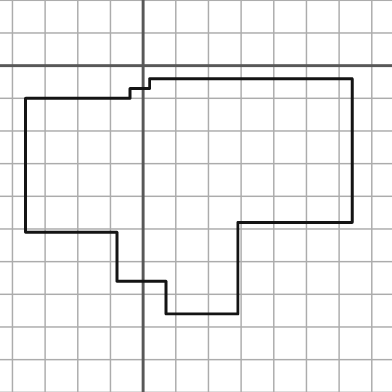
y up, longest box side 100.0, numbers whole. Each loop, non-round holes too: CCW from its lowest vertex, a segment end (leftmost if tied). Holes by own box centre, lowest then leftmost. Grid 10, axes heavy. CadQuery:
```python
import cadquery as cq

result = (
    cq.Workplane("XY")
    .moveTo(7.0, -76.0)
    .lineTo(29.0, -76.0)
    .lineTo(29.0, -48.0)
    .lineTo(64.0, -48.0)
    .lineTo(64.0, -4.0)
    .lineTo(2.0, -4.0)
    .lineTo(2.0, -7.0)
    .lineTo(-4.0, -7.0)
    .lineTo(-4.0, -10.0)
    .lineTo(-36.0, -10.0)
    .lineTo(-36.0, -51.0)
    .lineTo(-8.0, -51.0)
    .lineTo(-8.0, -66.0)
    .lineTo(7.0, -66.0)
    .close()
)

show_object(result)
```